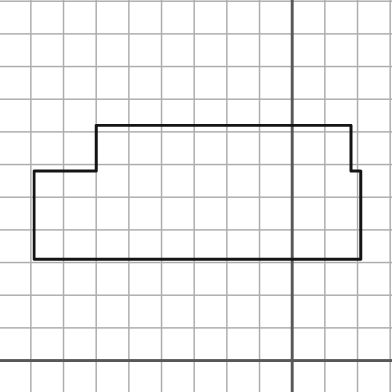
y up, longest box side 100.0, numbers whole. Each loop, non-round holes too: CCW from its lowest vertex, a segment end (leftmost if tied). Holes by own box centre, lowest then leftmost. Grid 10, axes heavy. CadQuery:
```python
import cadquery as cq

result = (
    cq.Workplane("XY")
    .moveTo(-79.0, 31.0)
    .lineTo(21.0, 31.0)
    .lineTo(21.0, 58.0)
    .lineTo(18.0, 58.0)
    .lineTo(18.0, 72.0)
    .lineTo(-60.0, 72.0)
    .lineTo(-60.0, 58.0)
    .lineTo(-79.0, 58.0)
    .close()
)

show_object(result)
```